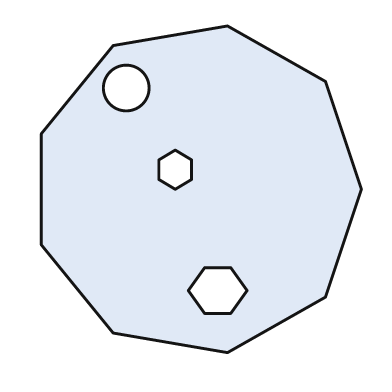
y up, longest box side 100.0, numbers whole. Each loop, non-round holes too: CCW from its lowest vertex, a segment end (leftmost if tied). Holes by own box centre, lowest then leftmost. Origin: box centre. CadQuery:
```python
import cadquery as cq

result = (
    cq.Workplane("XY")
    .moveTo(8.0, -50.0)
    .lineTo(38.0, -33.0)
    .lineTo(49.0, 0.0)
    .lineTo(38.0, 33.0)
    .lineTo(8.0, 50.0)
    .lineTo(-27.0, 44.0)
    .lineTo(-49.0, 17.0)
    .lineTo(-49.0, -17.0)
    .lineTo(-27.0, -44.0)
    .close()
    .moveTo(1.0, -38.0)
    .lineTo(9.0, -38.0)
    .lineTo(14.0, -31.0)
    .lineTo(9.0, -24.0)
    .lineTo(1.0, -24.0)
    .lineTo(-4.0, -31.0)
    .close()
    .moveTo(-8.0, 0.0)
    .lineTo(-3.0, 3.0)
    .lineTo(-3.0, 9.0)
    .lineTo(-8.0, 12.0)
    .lineTo(-13.0, 9.0)
    .lineTo(-13.0, 3.0)
    .close()
    .moveTo(-23.0, 31.0)
    .circle(7.0)
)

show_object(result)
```